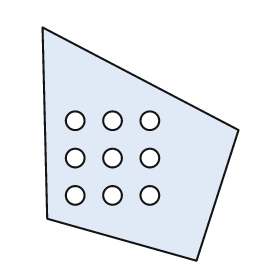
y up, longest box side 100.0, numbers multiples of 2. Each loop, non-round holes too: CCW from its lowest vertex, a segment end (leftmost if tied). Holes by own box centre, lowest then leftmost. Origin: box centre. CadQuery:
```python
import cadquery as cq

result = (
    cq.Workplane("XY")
    .moveTo(24.0, -50.0)
    .lineTo(42.0, 6.0)
    .lineTo(-42.0, 50.0)
    .lineTo(-40.0, -32.0)
    .close()
    .moveTo(-28.0, -22.0)
    .circle(4.0)
    .moveTo(-12.0, -22.0)
    .circle(4.0)
    .moveTo(4.0, -22.0)
    .circle(4.0)
    .moveTo(-28.0, -6.0)
    .circle(4.0)
    .moveTo(-12.0, -6.0)
    .circle(4.0)
    .moveTo(4.0, -6.0)
    .circle(4.0)
    .moveTo(-28.0, 10.0)
    .circle(4.0)
    .moveTo(-12.0, 10.0)
    .circle(4.0)
    .moveTo(4.0, 10.0)
    .circle(4.0)
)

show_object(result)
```